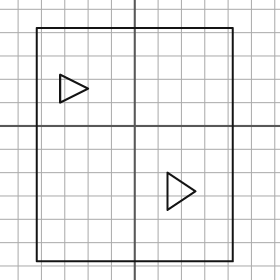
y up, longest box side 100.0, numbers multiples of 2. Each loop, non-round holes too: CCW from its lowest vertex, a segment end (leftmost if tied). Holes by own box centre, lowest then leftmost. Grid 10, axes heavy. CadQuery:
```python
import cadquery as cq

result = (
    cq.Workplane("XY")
    .moveTo(-42.0, -58.0)
    .lineTo(42.0, -58.0)
    .lineTo(42.0, 42.0)
    .lineTo(-42.0, 42.0)
    .close()
    .moveTo(14.0, -36.0)
    .lineTo(26.0, -28.0)
    .lineTo(14.0, -20.0)
    .close()
    .moveTo(-32.0, 10.0)
    .lineTo(-20.0, 16.0)
    .lineTo(-32.0, 22.0)
    .close()
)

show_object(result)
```